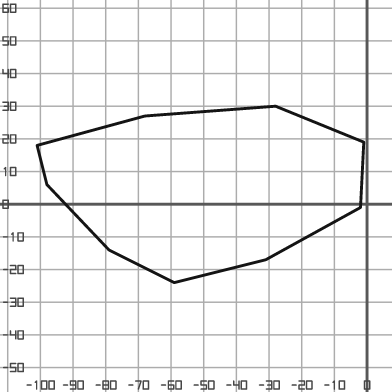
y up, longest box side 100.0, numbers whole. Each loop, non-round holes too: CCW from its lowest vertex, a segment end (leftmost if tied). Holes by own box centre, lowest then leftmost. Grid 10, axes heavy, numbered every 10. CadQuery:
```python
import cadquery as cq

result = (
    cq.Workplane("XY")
    .moveTo(-59.0, -24.0)
    .lineTo(-31.0, -17.0)
    .lineTo(-2.0, -1.0)
    .lineTo(-1.0, 19.0)
    .lineTo(-28.0, 30.0)
    .lineTo(-68.0, 27.0)
    .lineTo(-101.0, 18.0)
    .lineTo(-98.0, 6.0)
    .lineTo(-79.0, -14.0)
    .close()
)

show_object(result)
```